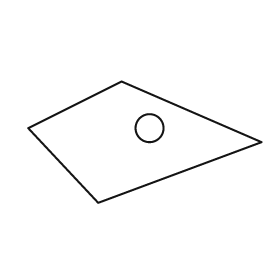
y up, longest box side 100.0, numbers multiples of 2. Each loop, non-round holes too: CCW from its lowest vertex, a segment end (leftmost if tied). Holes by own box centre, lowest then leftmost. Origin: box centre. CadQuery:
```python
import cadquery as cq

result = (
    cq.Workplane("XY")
    .moveTo(-20.0, -26.0)
    .lineTo(50.0, 0.0)
    .lineTo(-10.0, 26.0)
    .lineTo(-50.0, 6.0)
    .close()
    .moveTo(2.0, 6.0)
    .circle(6.0)
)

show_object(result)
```